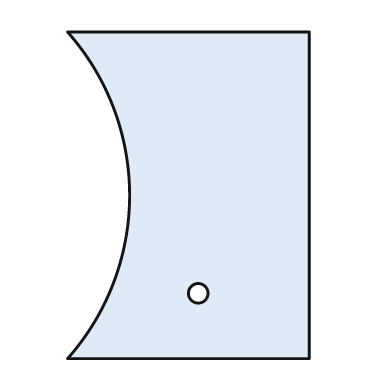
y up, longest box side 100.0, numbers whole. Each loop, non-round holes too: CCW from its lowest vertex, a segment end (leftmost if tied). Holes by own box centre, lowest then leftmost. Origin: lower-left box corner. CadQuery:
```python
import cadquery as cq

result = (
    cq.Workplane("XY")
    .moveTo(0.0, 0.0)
    .lineTo(74.0, 0.0)
    .lineTo(74.0, 100.0)
    .lineTo(0.0, 100.0)
    .threePointArc((19.0, 50.0), (0.0, 0.0))
    .close()
    .moveTo(40.0, 20.0)
    .circle(3.0)
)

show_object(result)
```